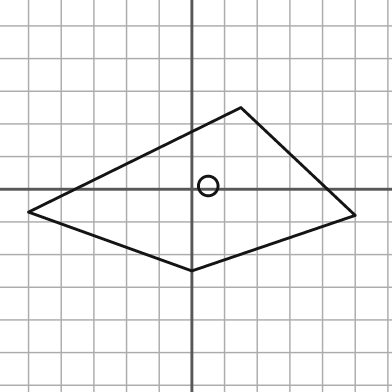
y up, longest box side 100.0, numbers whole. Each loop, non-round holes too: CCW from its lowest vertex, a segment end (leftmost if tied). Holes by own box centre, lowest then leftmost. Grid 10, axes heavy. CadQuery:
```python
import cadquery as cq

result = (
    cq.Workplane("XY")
    .moveTo(0.0, -25.0)
    .lineTo(50.0, -8.0)
    .lineTo(15.0, 25.0)
    .lineTo(-50.0, -7.0)
    .close()
    .moveTo(5.0, 1.0)
    .circle(3.0)
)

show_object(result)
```